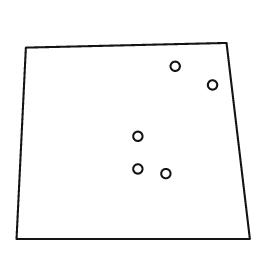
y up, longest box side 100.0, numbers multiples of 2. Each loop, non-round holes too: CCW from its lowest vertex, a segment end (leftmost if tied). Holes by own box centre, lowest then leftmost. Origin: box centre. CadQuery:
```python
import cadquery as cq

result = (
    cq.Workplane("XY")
    .moveTo(-50.0, -42.0)
    .lineTo(50.0, -42.0)
    .lineTo(40.0, 42.0)
    .lineTo(-46.0, 40.0)
    .close()
    .moveTo(14.0, -14.0)
    .circle(2.0)
    .moveTo(2.0, -12.0)
    .circle(2.0)
    .moveTo(2.0, 2.0)
    .circle(2.0)
    .moveTo(34.0, 24.0)
    .circle(2.0)
    .moveTo(18.0, 32.0)
    .circle(2.0)
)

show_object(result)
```